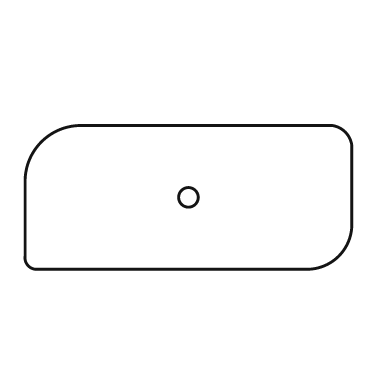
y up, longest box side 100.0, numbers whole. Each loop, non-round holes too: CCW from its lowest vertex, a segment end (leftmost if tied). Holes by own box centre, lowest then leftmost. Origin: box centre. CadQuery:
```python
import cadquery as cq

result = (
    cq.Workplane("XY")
    .moveTo(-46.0, -22.0)
    .lineTo(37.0, -22.0)
    .threePointArc((46.0, -18.0), (50.0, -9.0))
    .lineTo(50.0, 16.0)
    .threePointArc((48.0, 20.0), (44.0, 22.0))
    .lineTo(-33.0, 22.0)
    .threePointArc((-45.0, 17.0), (-50.0, 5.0))
    .lineTo(-50.0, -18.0)
    .threePointArc((-49.0, -21.0), (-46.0, -22.0))
    .close()
    .moveTo(0.0, 0.0)
    .circle(3.0)
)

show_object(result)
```